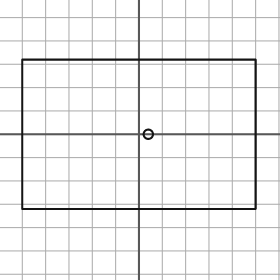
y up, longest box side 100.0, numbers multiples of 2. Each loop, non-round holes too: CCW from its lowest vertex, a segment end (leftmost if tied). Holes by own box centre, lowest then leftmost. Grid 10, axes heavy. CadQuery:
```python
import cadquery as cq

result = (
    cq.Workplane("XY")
    .moveTo(-50.0, -32.0)
    .lineTo(50.0, -32.0)
    .lineTo(50.0, 32.0)
    .lineTo(-50.0, 32.0)
    .close()
    .moveTo(4.0, 0.0)
    .circle(2.0)
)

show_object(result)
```